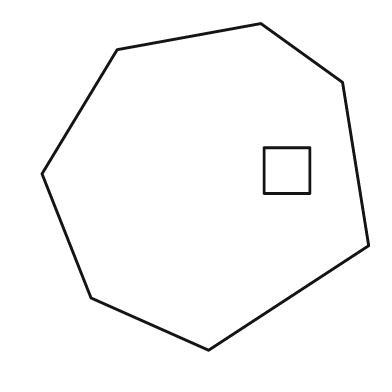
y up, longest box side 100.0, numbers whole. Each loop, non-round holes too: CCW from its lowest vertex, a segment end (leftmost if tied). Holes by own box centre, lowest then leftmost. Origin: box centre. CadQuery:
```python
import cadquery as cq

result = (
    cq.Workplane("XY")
    .moveTo(1.0, -50.0)
    .lineTo(50.0, -18.0)
    .lineTo(42.0, 32.0)
    .lineTo(17.0, 50.0)
    .lineTo(-27.0, 42.0)
    .lineTo(-50.0, 4.0)
    .lineTo(-35.0, -34.0)
    .close()
    .moveTo(18.0, -2.0)
    .lineTo(32.0, -2.0)
    .lineTo(32.0, 12.0)
    .lineTo(18.0, 12.0)
    .close()
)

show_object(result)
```